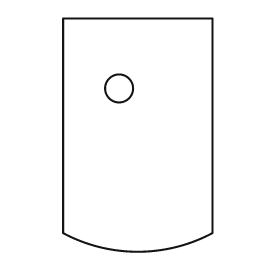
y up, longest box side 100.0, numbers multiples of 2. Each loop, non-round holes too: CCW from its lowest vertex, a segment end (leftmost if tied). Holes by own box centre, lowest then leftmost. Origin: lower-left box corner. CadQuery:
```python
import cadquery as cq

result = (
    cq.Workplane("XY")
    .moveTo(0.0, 8.0)
    .threePointArc((32.0, 0.0), (64.0, 8.0))
    .lineTo(64.0, 100.0)
    .lineTo(0.0, 100.0)
    .close()
    .moveTo(24.0, 70.0)
    .circle(6.0)
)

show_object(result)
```